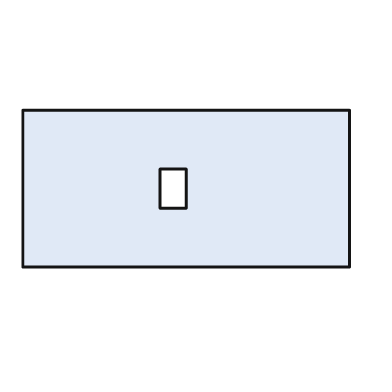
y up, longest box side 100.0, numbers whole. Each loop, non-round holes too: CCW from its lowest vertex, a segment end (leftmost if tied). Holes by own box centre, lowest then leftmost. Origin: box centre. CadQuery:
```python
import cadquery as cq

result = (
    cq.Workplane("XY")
    .moveTo(-50.0, -24.0)
    .lineTo(50.0, -24.0)
    .lineTo(50.0, 24.0)
    .lineTo(-50.0, 24.0)
    .close()
    .moveTo(-8.0, -6.0)
    .lineTo(0.0, -6.0)
    .lineTo(0.0, 6.0)
    .lineTo(-8.0, 6.0)
    .close()
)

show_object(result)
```